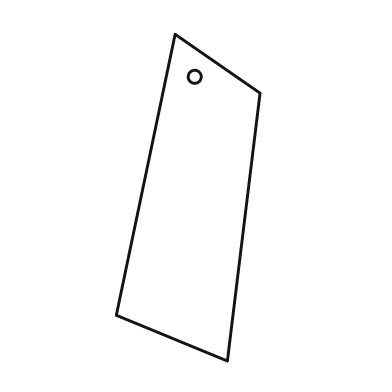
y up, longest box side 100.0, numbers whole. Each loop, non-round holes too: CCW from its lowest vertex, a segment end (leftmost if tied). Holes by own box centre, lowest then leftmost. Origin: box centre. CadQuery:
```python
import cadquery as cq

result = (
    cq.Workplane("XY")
    .moveTo(12.0, -50.0)
    .lineTo(22.0, 32.0)
    .lineTo(-4.0, 50.0)
    .lineTo(-22.0, -36.0)
    .close()
    .moveTo(2.0, 37.0)
    .circle(2.0)
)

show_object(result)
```